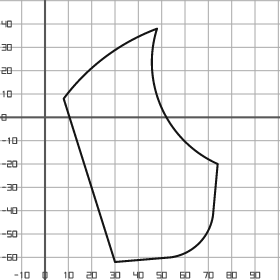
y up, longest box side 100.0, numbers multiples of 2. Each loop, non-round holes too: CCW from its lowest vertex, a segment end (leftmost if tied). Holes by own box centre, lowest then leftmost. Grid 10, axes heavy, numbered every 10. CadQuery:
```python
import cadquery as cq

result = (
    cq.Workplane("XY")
    .moveTo(30.0, -62.0)
    .lineTo(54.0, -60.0)
    .threePointArc((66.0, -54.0), (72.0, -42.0))
    .lineTo(74.0, -20.0)
    .threePointArc((50.0, 4.0), (48.0, 38.0))
    .threePointArc((26.0, 26.0), (8.0, 8.0))
    .close()
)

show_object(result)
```